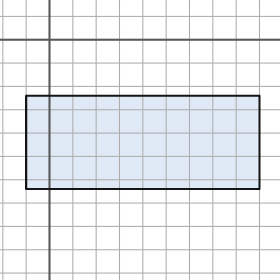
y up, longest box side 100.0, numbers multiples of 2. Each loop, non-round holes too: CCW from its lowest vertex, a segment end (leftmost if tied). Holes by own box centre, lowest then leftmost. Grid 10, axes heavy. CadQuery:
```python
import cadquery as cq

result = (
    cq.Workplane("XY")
    .moveTo(-10.0, -64.0)
    .lineTo(90.0, -64.0)
    .lineTo(90.0, -24.0)
    .lineTo(-10.0, -24.0)
    .close()
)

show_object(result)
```